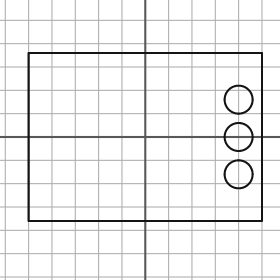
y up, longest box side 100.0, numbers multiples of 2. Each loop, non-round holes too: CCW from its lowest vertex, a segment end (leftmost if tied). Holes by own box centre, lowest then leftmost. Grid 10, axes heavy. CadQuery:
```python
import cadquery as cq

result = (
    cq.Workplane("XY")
    .moveTo(-50.0, -36.0)
    .lineTo(50.0, -36.0)
    .lineTo(50.0, 36.0)
    .lineTo(-50.0, 36.0)
    .close()
    .moveTo(40.0, -16.0)
    .circle(6.0)
    .moveTo(40.0, 0.0)
    .circle(6.0)
    .moveTo(40.0, 16.0)
    .circle(6.0)
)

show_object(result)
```